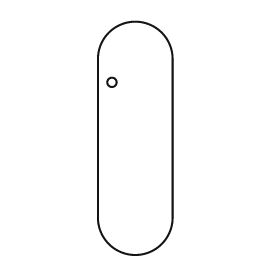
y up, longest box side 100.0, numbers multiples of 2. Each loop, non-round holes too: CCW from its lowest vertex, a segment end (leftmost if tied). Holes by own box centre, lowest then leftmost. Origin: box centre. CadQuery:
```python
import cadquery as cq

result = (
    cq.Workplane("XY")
    .moveTo(-16.0, -34.0)
    .threePointArc((0.0, -50.0), (16.0, -34.0))
    .lineTo(16.0, 34.0)
    .threePointArc((0.0, 50.0), (-16.0, 34.0))
    .close()
    .moveTo(-10.0, 24.0)
    .circle(2.0)
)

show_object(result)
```